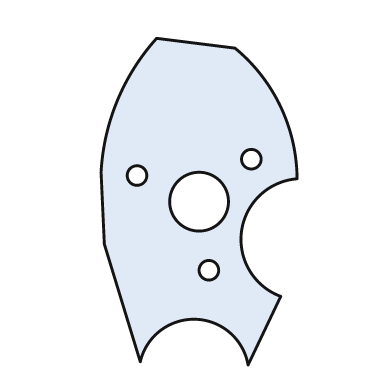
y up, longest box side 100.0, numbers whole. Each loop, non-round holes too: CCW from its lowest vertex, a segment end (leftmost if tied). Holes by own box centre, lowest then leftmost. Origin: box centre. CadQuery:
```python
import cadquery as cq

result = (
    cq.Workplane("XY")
    .moveTo(15.0, -50.0)
    .lineTo(25.0, -29.0)
    .threePointArc((13.0, -9.0), (30.0, 7.0))
    .threePointArc((25.0, 29.0), (11.0, 47.0))
    .lineTo(-13.0, 50.0)
    .threePointArc((-25.0, 31.0), (-30.0, 9.0))
    .lineTo(-29.0, -13.0)
    .lineTo(-18.0, -49.0)
    .threePointArc((-1.0, -36.0), (15.0, -50.0))
    .close()
    .moveTo(3.0, -21.0)
    .circle(3.0)
    .moveTo(0.0, 0.0)
    .circle(9.0)
    .moveTo(-19.0, 8.0)
    .circle(3.0)
    .moveTo(16.0, 13.0)
    .circle(3.0)
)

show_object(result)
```